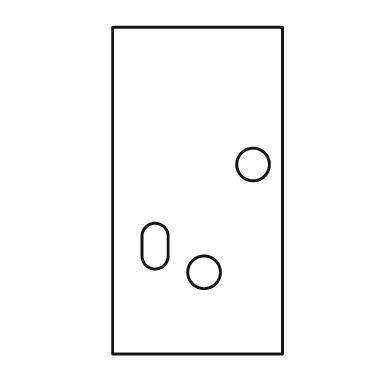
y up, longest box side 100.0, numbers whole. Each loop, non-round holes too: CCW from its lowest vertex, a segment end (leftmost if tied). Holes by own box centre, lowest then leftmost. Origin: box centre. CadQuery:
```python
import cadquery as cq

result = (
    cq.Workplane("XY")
    .moveTo(-26.0, -50.0)
    .lineTo(26.0, -50.0)
    .lineTo(26.0, 50.0)
    .lineTo(-26.0, 50.0)
    .close()
    .moveTo(2.0, -25.0)
    .circle(5.0)
    .moveTo(-17.0, -20.0)
    .threePointArc((-13.0, -24.0), (-9.0, -20.0))
    .lineTo(-9.0, -14.0)
    .threePointArc((-13.0, -10.0), (-17.0, -14.0))
    .close()
    .moveTo(17.0, 8.0)
    .circle(5.0)
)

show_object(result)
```